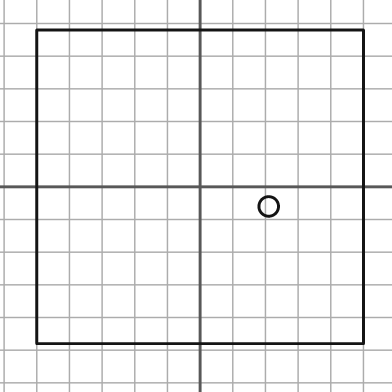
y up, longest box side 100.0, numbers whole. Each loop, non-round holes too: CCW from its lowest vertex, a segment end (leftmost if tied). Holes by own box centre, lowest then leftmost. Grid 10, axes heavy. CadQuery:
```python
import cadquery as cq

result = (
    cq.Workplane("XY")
    .moveTo(-50.0, -48.0)
    .lineTo(50.0, -48.0)
    .lineTo(50.0, 48.0)
    .lineTo(-50.0, 48.0)
    .close()
    .moveTo(21.0, -6.0)
    .circle(3.0)
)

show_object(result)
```